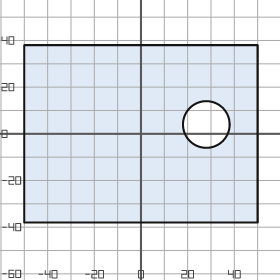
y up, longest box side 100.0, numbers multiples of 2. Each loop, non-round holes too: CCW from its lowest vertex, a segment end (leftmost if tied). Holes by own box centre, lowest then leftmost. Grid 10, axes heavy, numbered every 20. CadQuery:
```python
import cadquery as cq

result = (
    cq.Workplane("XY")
    .moveTo(-50.0, -38.0)
    .lineTo(50.0, -38.0)
    .lineTo(50.0, 38.0)
    .lineTo(-50.0, 38.0)
    .close()
    .moveTo(28.0, 4.0)
    .circle(10.0)
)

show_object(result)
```